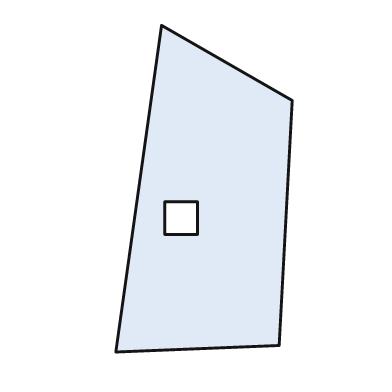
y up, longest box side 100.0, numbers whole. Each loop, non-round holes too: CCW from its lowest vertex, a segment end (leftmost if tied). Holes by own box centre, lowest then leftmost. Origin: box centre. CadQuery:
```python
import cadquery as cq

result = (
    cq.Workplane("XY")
    .moveTo(-27.0, -50.0)
    .lineTo(23.0, -48.0)
    .lineTo(27.0, 27.0)
    .lineTo(-13.0, 50.0)
    .close()
    .moveTo(-12.0, -14.0)
    .lineTo(-2.0, -14.0)
    .lineTo(-2.0, -4.0)
    .lineTo(-12.0, -4.0)
    .close()
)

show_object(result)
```